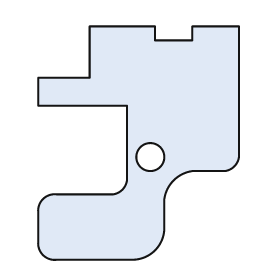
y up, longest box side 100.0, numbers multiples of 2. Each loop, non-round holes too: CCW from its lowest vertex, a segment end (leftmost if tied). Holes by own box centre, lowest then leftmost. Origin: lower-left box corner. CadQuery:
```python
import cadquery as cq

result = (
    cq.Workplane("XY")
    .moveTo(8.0, 0.0)
    .lineTo(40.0, 0.0)
    .threePointArc((50.0, 4.0), (54.0, 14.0))
    .lineTo(54.0, 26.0)
    .threePointArc((58.0, 34.0), (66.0, 38.0))
    .lineTo(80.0, 38.0)
    .threePointArc((84.0, 40.0), (86.0, 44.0))
    .lineTo(86.0, 100.0)
    .lineTo(66.0, 100.0)
    .lineTo(66.0, 94.0)
    .lineTo(50.0, 94.0)
    .lineTo(50.0, 100.0)
    .lineTo(22.0, 100.0)
    .lineTo(22.0, 78.0)
    .lineTo(0.0, 78.0)
    .lineTo(0.0, 66.0)
    .lineTo(38.0, 66.0)
    .lineTo(38.0, 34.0)
    .threePointArc((36.0, 30.0), (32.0, 28.0))
    .lineTo(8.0, 28.0)
    .threePointArc((2.0, 26.0), (0.0, 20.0))
    .lineTo(0.0, 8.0)
    .threePointArc((2.0, 2.0), (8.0, 0.0))
    .close()
    .moveTo(48.0, 44.0)
    .circle(6.0)
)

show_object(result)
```